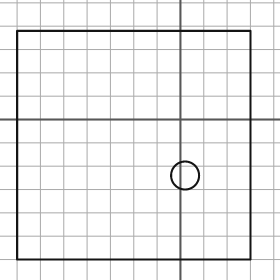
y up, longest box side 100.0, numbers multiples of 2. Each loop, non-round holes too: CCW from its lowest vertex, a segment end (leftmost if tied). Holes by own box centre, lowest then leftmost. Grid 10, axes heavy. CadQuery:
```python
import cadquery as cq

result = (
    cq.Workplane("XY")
    .moveTo(-70.0, -60.0)
    .lineTo(30.0, -60.0)
    .lineTo(30.0, 38.0)
    .lineTo(-70.0, 38.0)
    .close()
    .moveTo(2.0, -24.0)
    .circle(6.0)
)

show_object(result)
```